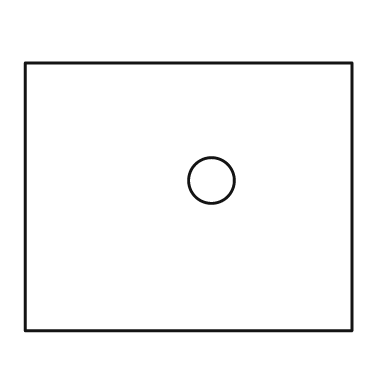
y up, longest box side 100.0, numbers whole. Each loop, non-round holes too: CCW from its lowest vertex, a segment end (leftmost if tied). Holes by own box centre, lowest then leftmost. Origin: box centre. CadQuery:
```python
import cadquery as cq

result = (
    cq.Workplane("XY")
    .moveTo(-50.0, -41.0)
    .lineTo(50.0, -41.0)
    .lineTo(50.0, 41.0)
    .lineTo(-50.0, 41.0)
    .close()
    .moveTo(7.0, 5.0)
    .circle(7.0)
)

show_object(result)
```